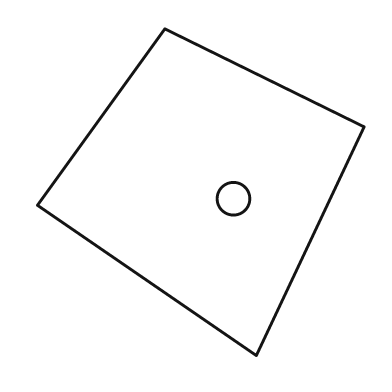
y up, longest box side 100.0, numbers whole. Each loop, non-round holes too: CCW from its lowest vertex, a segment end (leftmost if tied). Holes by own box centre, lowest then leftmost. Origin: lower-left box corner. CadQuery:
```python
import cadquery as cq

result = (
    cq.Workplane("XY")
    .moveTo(67.0, 0.0)
    .lineTo(100.0, 70.0)
    .lineTo(39.0, 100.0)
    .lineTo(0.0, 46.0)
    .close()
    .moveTo(60.0, 48.0)
    .circle(5.0)
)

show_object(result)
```